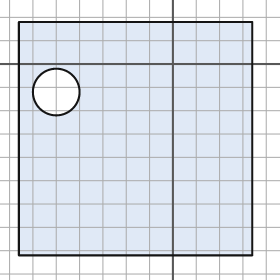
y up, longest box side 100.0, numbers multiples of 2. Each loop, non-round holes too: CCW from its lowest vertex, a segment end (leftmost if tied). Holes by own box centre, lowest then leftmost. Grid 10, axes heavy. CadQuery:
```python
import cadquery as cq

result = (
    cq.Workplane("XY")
    .moveTo(-66.0, -82.0)
    .lineTo(34.0, -82.0)
    .lineTo(34.0, 18.0)
    .lineTo(-66.0, 18.0)
    .close()
    .moveTo(-50.0, -12.0)
    .circle(10.0)
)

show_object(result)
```